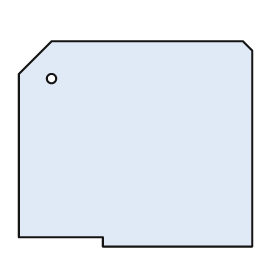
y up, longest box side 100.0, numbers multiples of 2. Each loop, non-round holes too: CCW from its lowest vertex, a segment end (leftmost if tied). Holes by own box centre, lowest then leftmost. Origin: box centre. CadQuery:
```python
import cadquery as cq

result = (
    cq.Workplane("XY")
    .moveTo(-14.0, -44.0)
    .lineTo(50.0, -44.0)
    .lineTo(50.0, 40.0)
    .lineTo(46.0, 44.0)
    .lineTo(-36.0, 44.0)
    .lineTo(-50.0, 30.0)
    .lineTo(-50.0, -40.0)
    .lineTo(-14.0, -40.0)
    .close()
    .moveTo(-36.0, 28.0)
    .circle(2.0)
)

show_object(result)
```